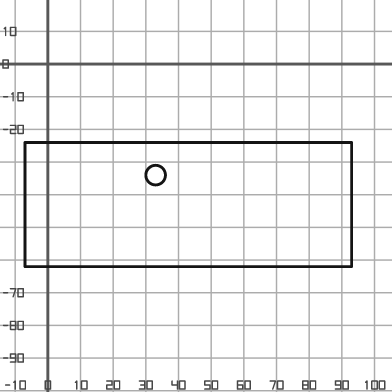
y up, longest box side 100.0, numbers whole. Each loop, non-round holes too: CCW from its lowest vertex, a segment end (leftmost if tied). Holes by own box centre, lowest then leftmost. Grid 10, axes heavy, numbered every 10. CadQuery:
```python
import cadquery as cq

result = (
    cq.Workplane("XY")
    .moveTo(-7.0, -62.0)
    .lineTo(93.0, -62.0)
    .lineTo(93.0, -24.0)
    .lineTo(-7.0, -24.0)
    .close()
    .moveTo(33.0, -34.0)
    .circle(3.0)
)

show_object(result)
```